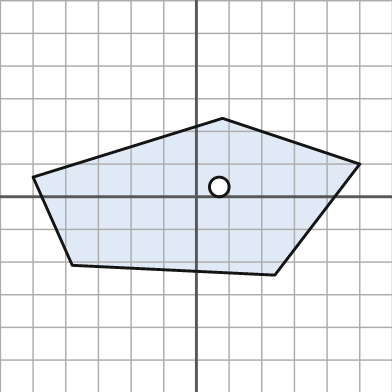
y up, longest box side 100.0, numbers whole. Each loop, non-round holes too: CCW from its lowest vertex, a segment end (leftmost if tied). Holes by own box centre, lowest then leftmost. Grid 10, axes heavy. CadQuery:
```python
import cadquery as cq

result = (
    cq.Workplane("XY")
    .moveTo(24.0, -24.0)
    .lineTo(50.0, 10.0)
    .lineTo(8.0, 24.0)
    .lineTo(-50.0, 6.0)
    .lineTo(-38.0, -21.0)
    .close()
    .moveTo(7.0, 3.0)
    .circle(3.0)
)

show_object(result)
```